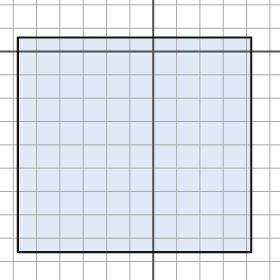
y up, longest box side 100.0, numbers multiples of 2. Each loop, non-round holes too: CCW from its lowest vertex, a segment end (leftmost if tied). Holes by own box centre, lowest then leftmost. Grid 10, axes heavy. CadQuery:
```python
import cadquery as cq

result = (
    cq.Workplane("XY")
    .moveTo(-58.0, -86.0)
    .lineTo(42.0, -86.0)
    .lineTo(42.0, 6.0)
    .lineTo(-58.0, 6.0)
    .close()
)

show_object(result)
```